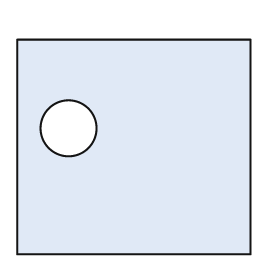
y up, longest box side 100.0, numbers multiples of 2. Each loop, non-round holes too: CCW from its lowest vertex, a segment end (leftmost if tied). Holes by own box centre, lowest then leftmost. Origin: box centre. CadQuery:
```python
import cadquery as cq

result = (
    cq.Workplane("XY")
    .moveTo(-50.0, -46.0)
    .lineTo(50.0, -46.0)
    .lineTo(50.0, 46.0)
    .lineTo(-50.0, 46.0)
    .close()
    .moveTo(-28.0, 8.0)
    .circle(12.0)
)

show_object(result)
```